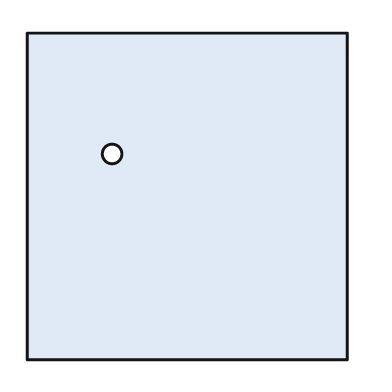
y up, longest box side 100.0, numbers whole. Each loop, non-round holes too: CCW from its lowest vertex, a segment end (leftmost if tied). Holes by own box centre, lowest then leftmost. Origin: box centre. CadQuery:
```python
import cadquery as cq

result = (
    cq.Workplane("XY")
    .moveTo(-49.0, -50.0)
    .lineTo(49.0, -50.0)
    .lineTo(49.0, 50.0)
    .lineTo(-49.0, 50.0)
    .close()
    .moveTo(-23.0, 13.0)
    .circle(3.0)
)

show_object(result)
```